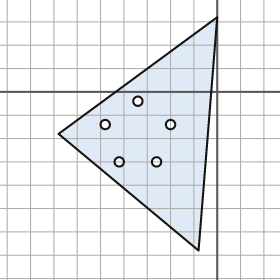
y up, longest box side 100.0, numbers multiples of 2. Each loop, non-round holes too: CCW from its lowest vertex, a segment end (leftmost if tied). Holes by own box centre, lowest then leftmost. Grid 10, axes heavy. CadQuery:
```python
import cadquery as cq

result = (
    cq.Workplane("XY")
    .moveTo(-8.0, -68.0)
    .lineTo(0.0, 32.0)
    .lineTo(-68.0, -18.0)
    .close()
    .moveTo(-42.0, -30.0)
    .circle(2.0)
    .moveTo(-26.0, -30.0)
    .circle(2.0)
    .moveTo(-48.0, -14.0)
    .circle(2.0)
    .moveTo(-20.0, -14.0)
    .circle(2.0)
    .moveTo(-34.0, -4.0)
    .circle(2.0)
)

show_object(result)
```